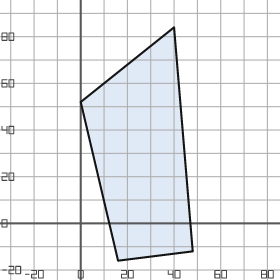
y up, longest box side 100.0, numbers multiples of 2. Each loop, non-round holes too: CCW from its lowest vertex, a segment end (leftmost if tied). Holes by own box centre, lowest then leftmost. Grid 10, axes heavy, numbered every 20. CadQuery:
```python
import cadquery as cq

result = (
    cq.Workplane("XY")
    .moveTo(16.0, -16.0)
    .lineTo(48.0, -12.0)
    .lineTo(40.0, 84.0)
    .lineTo(0.0, 52.0)
    .close()
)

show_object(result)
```